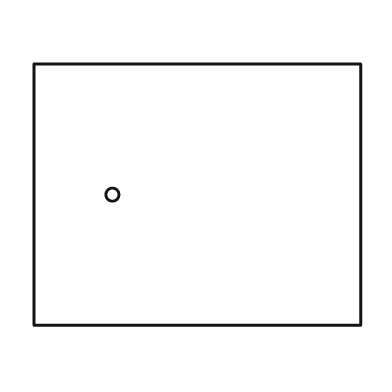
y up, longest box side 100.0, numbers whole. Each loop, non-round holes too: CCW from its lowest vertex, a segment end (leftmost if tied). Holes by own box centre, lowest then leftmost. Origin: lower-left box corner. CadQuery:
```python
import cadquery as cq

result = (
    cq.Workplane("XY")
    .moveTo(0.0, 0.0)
    .lineTo(100.0, 0.0)
    .lineTo(100.0, 80.0)
    .lineTo(0.0, 80.0)
    .close()
    .moveTo(24.0, 40.0)
    .circle(2.0)
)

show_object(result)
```